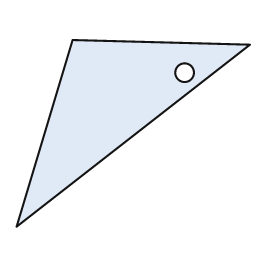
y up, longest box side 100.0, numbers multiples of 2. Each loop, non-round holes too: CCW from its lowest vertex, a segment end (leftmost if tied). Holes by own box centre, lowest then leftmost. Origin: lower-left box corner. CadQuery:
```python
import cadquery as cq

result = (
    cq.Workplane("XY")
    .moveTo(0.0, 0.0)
    .lineTo(100.0, 78.0)
    .lineTo(24.0, 80.0)
    .close()
    .moveTo(72.0, 66.0)
    .circle(4.0)
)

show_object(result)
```